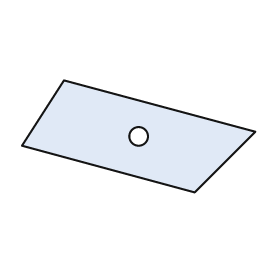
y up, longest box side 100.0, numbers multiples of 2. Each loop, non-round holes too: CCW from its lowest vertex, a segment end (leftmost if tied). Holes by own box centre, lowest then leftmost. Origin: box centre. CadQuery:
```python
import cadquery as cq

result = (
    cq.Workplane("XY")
    .moveTo(24.0, -24.0)
    .lineTo(50.0, 2.0)
    .lineTo(-32.0, 24.0)
    .lineTo(-50.0, -4.0)
    .close()
    .moveTo(0.0, 0.0)
    .circle(4.0)
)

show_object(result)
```